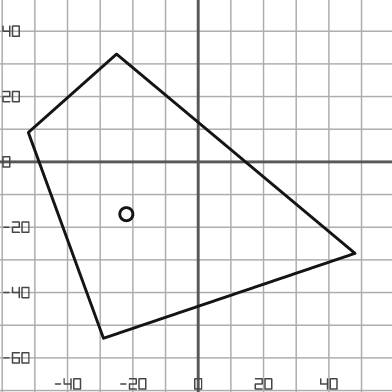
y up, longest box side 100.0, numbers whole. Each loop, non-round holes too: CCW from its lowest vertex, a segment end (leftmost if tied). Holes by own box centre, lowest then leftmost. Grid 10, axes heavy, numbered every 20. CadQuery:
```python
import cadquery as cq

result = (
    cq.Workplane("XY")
    .moveTo(-29.0, -54.0)
    .lineTo(48.0, -28.0)
    .lineTo(-25.0, 33.0)
    .lineTo(-52.0, 9.0)
    .close()
    .moveTo(-22.0, -16.0)
    .circle(2.0)
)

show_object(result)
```